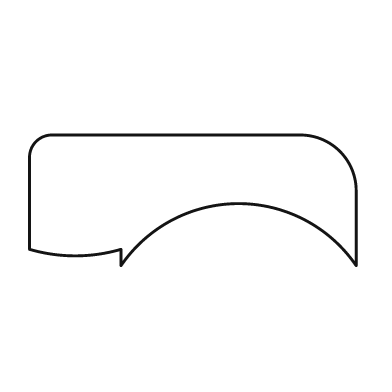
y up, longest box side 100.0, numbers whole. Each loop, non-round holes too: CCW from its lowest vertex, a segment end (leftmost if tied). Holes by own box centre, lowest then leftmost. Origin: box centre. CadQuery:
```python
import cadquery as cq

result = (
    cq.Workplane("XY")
    .moveTo(-22.0, -20.0)
    .threePointArc((14.0, -1.0), (50.0, -20.0))
    .lineTo(50.0, 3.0)
    .threePointArc((45.0, 15.0), (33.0, 20.0))
    .lineTo(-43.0, 20.0)
    .threePointArc((-48.0, 18.0), (-50.0, 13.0))
    .lineTo(-50.0, -15.0)
    .threePointArc((-36.0, -17.0), (-22.0, -15.0))
    .close()
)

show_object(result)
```